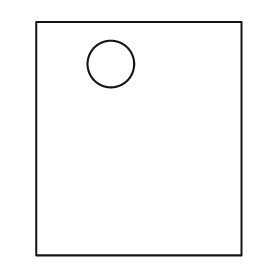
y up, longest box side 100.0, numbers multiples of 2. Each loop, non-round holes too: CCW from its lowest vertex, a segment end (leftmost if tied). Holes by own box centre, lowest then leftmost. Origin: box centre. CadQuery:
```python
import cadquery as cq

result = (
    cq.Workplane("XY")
    .moveTo(-44.0, -50.0)
    .lineTo(44.0, -50.0)
    .lineTo(44.0, 50.0)
    .lineTo(-44.0, 50.0)
    .close()
    .moveTo(-12.0, 32.0)
    .circle(10.0)
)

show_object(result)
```